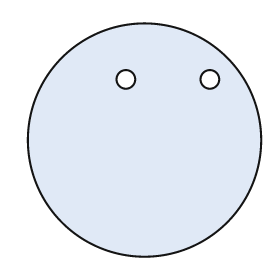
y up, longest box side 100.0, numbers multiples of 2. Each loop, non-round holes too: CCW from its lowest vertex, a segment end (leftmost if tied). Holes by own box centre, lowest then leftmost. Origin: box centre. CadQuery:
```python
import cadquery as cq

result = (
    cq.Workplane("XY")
    .moveTo(0.0, 0.0)
    .circle(50.0)
    .moveTo(-8.0, 26.0)
    .circle(4.0)
    .moveTo(28.0, 26.0)
    .circle(4.0)
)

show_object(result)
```